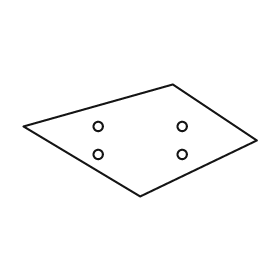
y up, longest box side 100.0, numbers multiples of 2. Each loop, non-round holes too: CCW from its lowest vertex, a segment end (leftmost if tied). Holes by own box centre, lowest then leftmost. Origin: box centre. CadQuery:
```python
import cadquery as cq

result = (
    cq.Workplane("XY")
    .moveTo(0.0, -24.0)
    .lineTo(50.0, 0.0)
    .lineTo(14.0, 24.0)
    .lineTo(-50.0, 6.0)
    .close()
    .moveTo(-18.0, -6.0)
    .circle(2.0)
    .moveTo(18.0, -6.0)
    .circle(2.0)
    .moveTo(-18.0, 6.0)
    .circle(2.0)
    .moveTo(18.0, 6.0)
    .circle(2.0)
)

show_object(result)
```